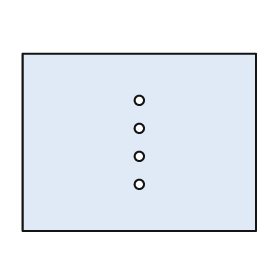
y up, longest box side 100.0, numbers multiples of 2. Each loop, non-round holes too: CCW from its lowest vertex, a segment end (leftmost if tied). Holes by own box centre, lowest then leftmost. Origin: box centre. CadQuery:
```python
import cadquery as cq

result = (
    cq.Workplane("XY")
    .moveTo(-50.0, -38.0)
    .lineTo(50.0, -38.0)
    .lineTo(50.0, 38.0)
    .lineTo(-50.0, 38.0)
    .close()
    .moveTo(0.0, -18.0)
    .circle(2.0)
    .moveTo(0.0, -6.0)
    .circle(2.0)
    .moveTo(0.0, 6.0)
    .circle(2.0)
    .moveTo(0.0, 18.0)
    .circle(2.0)
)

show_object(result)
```